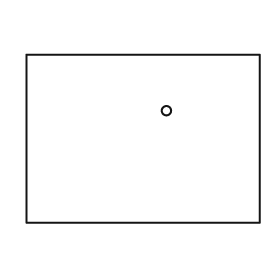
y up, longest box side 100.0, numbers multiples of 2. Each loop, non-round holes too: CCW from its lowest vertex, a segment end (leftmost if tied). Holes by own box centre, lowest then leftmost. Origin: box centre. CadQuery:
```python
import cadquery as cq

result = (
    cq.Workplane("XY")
    .moveTo(-50.0, -36.0)
    .lineTo(50.0, -36.0)
    .lineTo(50.0, 36.0)
    .lineTo(-50.0, 36.0)
    .close()
    .moveTo(10.0, 12.0)
    .circle(2.0)
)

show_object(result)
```